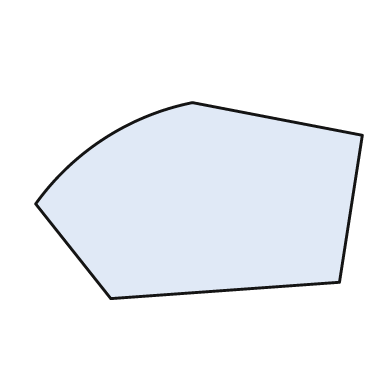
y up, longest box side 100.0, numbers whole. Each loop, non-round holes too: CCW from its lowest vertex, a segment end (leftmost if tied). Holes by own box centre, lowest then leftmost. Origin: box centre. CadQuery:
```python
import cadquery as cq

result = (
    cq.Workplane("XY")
    .moveTo(-27.0, -30.0)
    .lineTo(43.0, -25.0)
    .lineTo(50.0, 20.0)
    .lineTo(-2.0, 30.0)
    .threePointArc((-29.0, 19.0), (-50.0, -1.0))
    .close()
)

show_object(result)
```